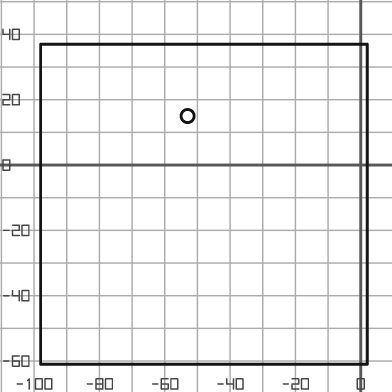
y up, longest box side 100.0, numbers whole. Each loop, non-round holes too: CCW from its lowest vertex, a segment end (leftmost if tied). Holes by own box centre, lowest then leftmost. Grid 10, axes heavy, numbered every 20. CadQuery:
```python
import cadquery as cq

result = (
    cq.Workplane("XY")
    .moveTo(-98.0, -61.0)
    .lineTo(2.0, -61.0)
    .lineTo(2.0, 37.0)
    .lineTo(-98.0, 37.0)
    .close()
    .moveTo(-53.0, 15.0)
    .circle(2.0)
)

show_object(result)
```